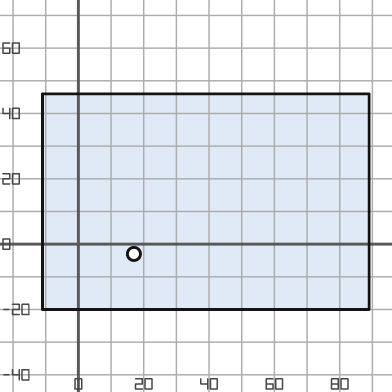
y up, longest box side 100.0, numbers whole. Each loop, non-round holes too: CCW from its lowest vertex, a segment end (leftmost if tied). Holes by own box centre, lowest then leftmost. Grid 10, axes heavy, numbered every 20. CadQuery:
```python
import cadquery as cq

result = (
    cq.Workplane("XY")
    .moveTo(-11.0, -20.0)
    .lineTo(89.0, -20.0)
    .lineTo(89.0, 46.0)
    .lineTo(-11.0, 46.0)
    .close()
    .moveTo(17.0, -3.0)
    .circle(2.0)
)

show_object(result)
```